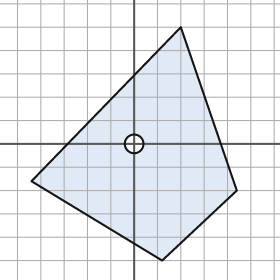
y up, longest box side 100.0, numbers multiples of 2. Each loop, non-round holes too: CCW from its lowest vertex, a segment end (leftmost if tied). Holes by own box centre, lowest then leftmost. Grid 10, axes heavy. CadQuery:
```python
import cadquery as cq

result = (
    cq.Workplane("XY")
    .moveTo(12.0, -50.0)
    .lineTo(44.0, -20.0)
    .lineTo(20.0, 50.0)
    .lineTo(-44.0, -16.0)
    .close()
    .moveTo(0.0, 0.0)
    .circle(4.0)
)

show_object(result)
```